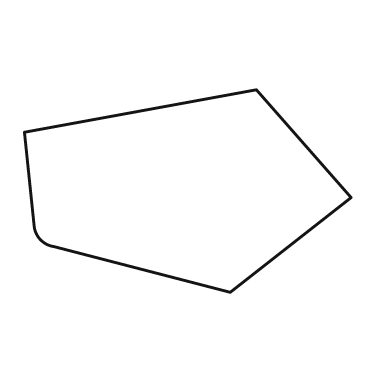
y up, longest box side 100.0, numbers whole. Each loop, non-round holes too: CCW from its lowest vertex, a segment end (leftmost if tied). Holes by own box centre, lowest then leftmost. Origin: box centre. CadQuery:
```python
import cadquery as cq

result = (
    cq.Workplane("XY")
    .moveTo(13.0, -31.0)
    .lineTo(50.0, -2.0)
    .lineTo(21.0, 31.0)
    .lineTo(-50.0, 18.0)
    .lineTo(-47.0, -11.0)
    .threePointArc((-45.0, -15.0), (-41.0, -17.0))
    .close()
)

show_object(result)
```